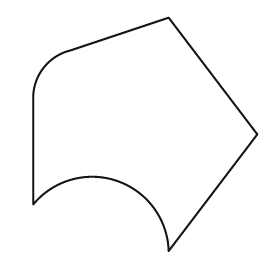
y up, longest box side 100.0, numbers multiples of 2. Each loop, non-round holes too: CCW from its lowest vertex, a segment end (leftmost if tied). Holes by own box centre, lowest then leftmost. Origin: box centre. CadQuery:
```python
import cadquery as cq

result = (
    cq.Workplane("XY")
    .moveTo(10.0, -50.0)
    .lineTo(48.0, 0.0)
    .lineTo(10.0, 50.0)
    .lineTo(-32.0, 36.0)
    .threePointArc((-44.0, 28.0), (-48.0, 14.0))
    .lineTo(-48.0, -30.0)
    .threePointArc((-12.0, -20.0), (10.0, -50.0))
    .close()
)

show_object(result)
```